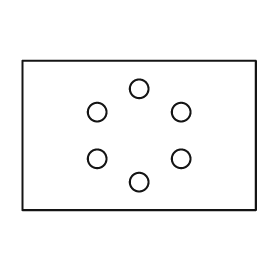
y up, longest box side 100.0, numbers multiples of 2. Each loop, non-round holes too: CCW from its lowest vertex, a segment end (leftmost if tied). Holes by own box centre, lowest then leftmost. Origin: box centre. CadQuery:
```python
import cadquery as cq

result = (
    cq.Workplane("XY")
    .moveTo(-50.0, -32.0)
    .lineTo(50.0, -32.0)
    .lineTo(50.0, 32.0)
    .lineTo(-50.0, 32.0)
    .close()
    .moveTo(0.0, -20.0)
    .circle(4.0)
    .moveTo(-18.0, -10.0)
    .circle(4.0)
    .moveTo(18.0, -10.0)
    .circle(4.0)
    .moveTo(-18.0, 10.0)
    .circle(4.0)
    .moveTo(18.0, 10.0)
    .circle(4.0)
    .moveTo(0.0, 20.0)
    .circle(4.0)
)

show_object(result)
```